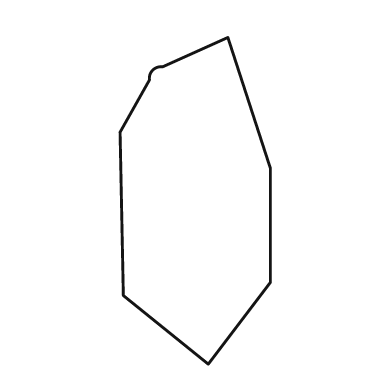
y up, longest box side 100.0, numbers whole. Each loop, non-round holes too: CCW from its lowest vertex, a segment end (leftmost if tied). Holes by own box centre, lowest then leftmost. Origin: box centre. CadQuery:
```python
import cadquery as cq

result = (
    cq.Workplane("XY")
    .moveTo(4.0, -50.0)
    .lineTo(23.0, -25.0)
    .lineTo(23.0, 10.0)
    .lineTo(10.0, 50.0)
    .lineTo(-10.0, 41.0)
    .threePointArc((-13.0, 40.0), (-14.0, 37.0))
    .lineTo(-23.0, 21.0)
    .lineTo(-22.0, -29.0)
    .close()
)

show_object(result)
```